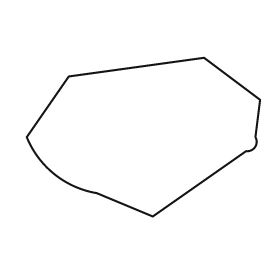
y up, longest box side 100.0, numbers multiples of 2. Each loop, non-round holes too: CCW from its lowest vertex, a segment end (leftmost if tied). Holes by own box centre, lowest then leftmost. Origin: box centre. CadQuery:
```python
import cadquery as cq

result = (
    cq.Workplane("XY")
    .moveTo(4.0, -34.0)
    .lineTo(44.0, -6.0)
    .threePointArc((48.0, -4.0), (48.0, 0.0))
    .lineTo(50.0, 16.0)
    .lineTo(26.0, 34.0)
    .lineTo(-32.0, 26.0)
    .lineTo(-50.0, 0.0)
    .threePointArc((-38.0, -16.0), (-20.0, -24.0))
    .close()
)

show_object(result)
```